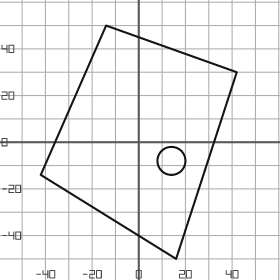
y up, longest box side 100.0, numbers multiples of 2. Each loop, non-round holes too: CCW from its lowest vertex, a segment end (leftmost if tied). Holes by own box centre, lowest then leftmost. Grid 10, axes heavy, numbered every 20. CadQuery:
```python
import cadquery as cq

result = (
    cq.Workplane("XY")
    .moveTo(16.0, -50.0)
    .lineTo(42.0, 30.0)
    .lineTo(-14.0, 50.0)
    .lineTo(-42.0, -14.0)
    .close()
    .moveTo(14.0, -8.0)
    .circle(6.0)
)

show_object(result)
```